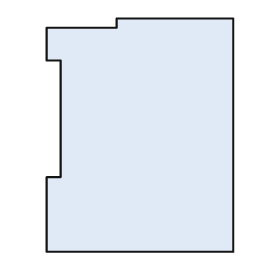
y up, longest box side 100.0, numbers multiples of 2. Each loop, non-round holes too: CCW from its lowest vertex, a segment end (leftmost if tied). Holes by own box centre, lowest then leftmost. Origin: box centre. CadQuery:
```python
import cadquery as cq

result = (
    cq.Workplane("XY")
    .moveTo(-40.0, -50.0)
    .lineTo(40.0, -50.0)
    .lineTo(40.0, 50.0)
    .lineTo(-10.0, 50.0)
    .lineTo(-10.0, 46.0)
    .lineTo(-40.0, 46.0)
    .lineTo(-40.0, 32.0)
    .lineTo(-34.0, 32.0)
    .lineTo(-34.0, -18.0)
    .lineTo(-40.0, -18.0)
    .close()
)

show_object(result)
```